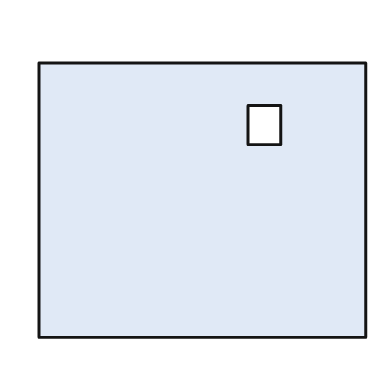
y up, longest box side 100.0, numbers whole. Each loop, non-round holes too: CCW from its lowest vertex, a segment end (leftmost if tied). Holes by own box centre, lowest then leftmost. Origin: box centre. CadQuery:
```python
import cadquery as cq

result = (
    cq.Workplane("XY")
    .moveTo(-50.0, -42.0)
    .lineTo(50.0, -42.0)
    .lineTo(50.0, 42.0)
    .lineTo(-50.0, 42.0)
    .close()
    .moveTo(14.0, 17.0)
    .lineTo(24.0, 17.0)
    .lineTo(24.0, 29.0)
    .lineTo(14.0, 29.0)
    .close()
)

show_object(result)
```